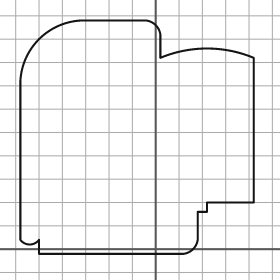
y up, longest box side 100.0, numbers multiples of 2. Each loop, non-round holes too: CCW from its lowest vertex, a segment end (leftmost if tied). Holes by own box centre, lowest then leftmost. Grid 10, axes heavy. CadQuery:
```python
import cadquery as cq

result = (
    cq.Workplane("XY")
    .moveTo(-50.0, -2.0)
    .lineTo(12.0, -2.0)
    .threePointArc((16.0, 0.0), (18.0, 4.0))
    .lineTo(18.0, 16.0)
    .lineTo(22.0, 16.0)
    .lineTo(22.0, 20.0)
    .lineTo(42.0, 20.0)
    .lineTo(42.0, 82.0)
    .threePointArc((22.0, 86.0), (2.0, 82.0))
    .lineTo(2.0, 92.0)
    .threePointArc((0.0, 96.0), (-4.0, 98.0))
    .lineTo(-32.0, 98.0)
    .threePointArc((-50.0, 90.0), (-58.0, 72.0))
    .lineTo(-58.0, 4.0)
    .threePointArc((-54.0, 2.0), (-50.0, 4.0))
    .close()
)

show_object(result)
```